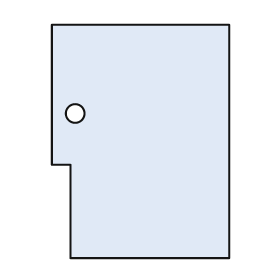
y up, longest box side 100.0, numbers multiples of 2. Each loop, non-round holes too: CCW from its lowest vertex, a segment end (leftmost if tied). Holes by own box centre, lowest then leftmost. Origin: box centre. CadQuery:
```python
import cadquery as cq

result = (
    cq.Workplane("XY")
    .moveTo(-30.0, -50.0)
    .lineTo(38.0, -50.0)
    .lineTo(38.0, 50.0)
    .lineTo(-38.0, 50.0)
    .lineTo(-38.0, -10.0)
    .lineTo(-30.0, -10.0)
    .close()
    .moveTo(-28.0, 12.0)
    .circle(4.0)
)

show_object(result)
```